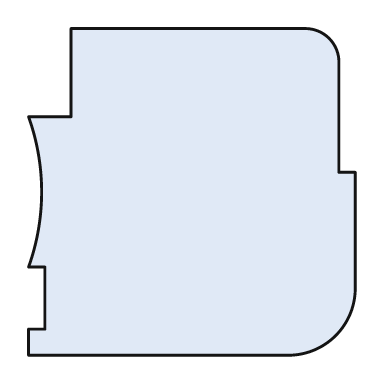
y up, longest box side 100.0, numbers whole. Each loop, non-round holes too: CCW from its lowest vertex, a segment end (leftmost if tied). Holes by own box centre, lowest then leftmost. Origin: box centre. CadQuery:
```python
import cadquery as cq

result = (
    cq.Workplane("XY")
    .moveTo(-50.0, -50.0)
    .lineTo(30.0, -50.0)
    .threePointArc((44.0, -44.0), (50.0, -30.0))
    .lineTo(50.0, 6.0)
    .lineTo(45.0, 6.0)
    .lineTo(45.0, 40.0)
    .threePointArc((42.0, 47.0), (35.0, 50.0))
    .lineTo(-37.0, 50.0)
    .lineTo(-37.0, 23.0)
    .lineTo(-50.0, 23.0)
    .threePointArc((-46.0, 0.0), (-50.0, -23.0))
    .lineTo(-45.0, -23.0)
    .lineTo(-45.0, -42.0)
    .lineTo(-50.0, -42.0)
    .close()
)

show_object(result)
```